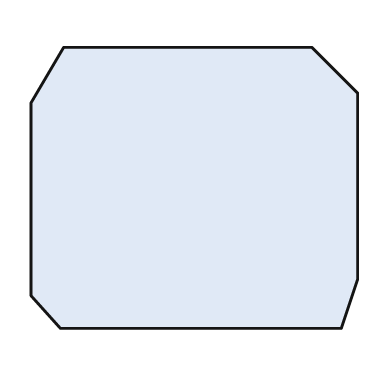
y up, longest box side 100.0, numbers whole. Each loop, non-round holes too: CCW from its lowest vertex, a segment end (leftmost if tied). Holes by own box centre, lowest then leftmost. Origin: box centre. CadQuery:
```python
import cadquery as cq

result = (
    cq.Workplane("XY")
    .moveTo(-41.0, -43.0)
    .lineTo(45.0, -43.0)
    .lineTo(50.0, -28.0)
    .lineTo(50.0, 29.0)
    .lineTo(36.0, 43.0)
    .lineTo(-40.0, 43.0)
    .lineTo(-50.0, 26.0)
    .lineTo(-50.0, -33.0)
    .close()
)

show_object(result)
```